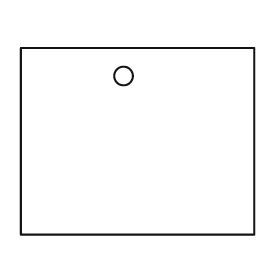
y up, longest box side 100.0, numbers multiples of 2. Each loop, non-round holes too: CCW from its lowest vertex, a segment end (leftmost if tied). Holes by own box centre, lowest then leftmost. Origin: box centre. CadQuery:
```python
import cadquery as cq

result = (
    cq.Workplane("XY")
    .moveTo(-50.0, -40.0)
    .lineTo(50.0, -40.0)
    .lineTo(50.0, 40.0)
    .lineTo(-50.0, 40.0)
    .close()
    .moveTo(-6.0, 28.0)
    .circle(4.0)
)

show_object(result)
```